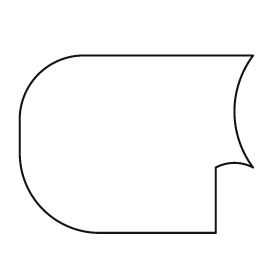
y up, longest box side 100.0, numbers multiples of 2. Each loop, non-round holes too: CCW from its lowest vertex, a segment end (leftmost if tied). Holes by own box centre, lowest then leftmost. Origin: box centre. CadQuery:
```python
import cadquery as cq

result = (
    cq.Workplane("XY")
    .moveTo(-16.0, -38.0)
    .lineTo(34.0, -38.0)
    .lineTo(34.0, -10.0)
    .threePointArc((42.0, -8.0), (50.0, -10.0))
    .threePointArc((42.0, 14.0), (50.0, 38.0))
    .lineTo(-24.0, 38.0)
    .threePointArc((-42.0, 30.0), (-50.0, 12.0))
    .lineTo(-50.0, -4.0)
    .threePointArc((-40.0, -28.0), (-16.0, -38.0))
    .close()
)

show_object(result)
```